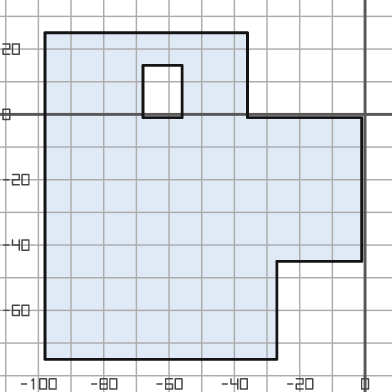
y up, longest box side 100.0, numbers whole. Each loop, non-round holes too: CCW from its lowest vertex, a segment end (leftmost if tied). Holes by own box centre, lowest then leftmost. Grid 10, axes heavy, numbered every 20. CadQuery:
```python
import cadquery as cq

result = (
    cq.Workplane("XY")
    .moveTo(-98.0, -75.0)
    .lineTo(-27.0, -75.0)
    .lineTo(-27.0, -45.0)
    .lineTo(-1.0, -45.0)
    .lineTo(-1.0, -1.0)
    .lineTo(-36.0, -1.0)
    .lineTo(-36.0, 25.0)
    .lineTo(-98.0, 25.0)
    .close()
    .moveTo(-68.0, -1.0)
    .lineTo(-56.0, -1.0)
    .lineTo(-56.0, 15.0)
    .lineTo(-68.0, 15.0)
    .close()
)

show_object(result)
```